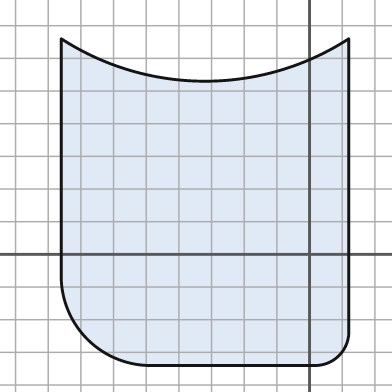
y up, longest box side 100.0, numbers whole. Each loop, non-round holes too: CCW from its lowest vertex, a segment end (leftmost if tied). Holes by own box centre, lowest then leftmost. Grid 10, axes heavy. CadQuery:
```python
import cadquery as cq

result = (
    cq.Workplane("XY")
    .moveTo(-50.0, -34.0)
    .lineTo(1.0, -34.0)
    .threePointArc((9.0, -31.0), (12.0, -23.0))
    .lineTo(12.0, 66.0)
    .threePointArc((-32.0, 53.0), (-76.0, 66.0))
    .lineTo(-76.0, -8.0)
    .threePointArc((-68.0, -26.0), (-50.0, -34.0))
    .close()
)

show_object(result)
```